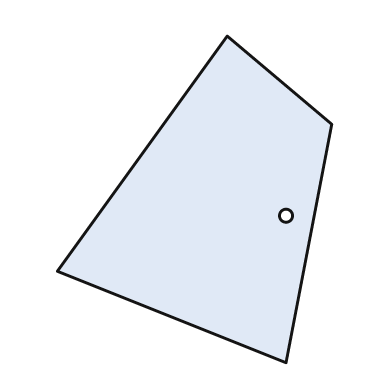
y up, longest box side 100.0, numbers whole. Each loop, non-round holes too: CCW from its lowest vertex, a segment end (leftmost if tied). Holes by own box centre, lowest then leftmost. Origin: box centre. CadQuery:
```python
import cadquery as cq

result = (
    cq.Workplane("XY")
    .moveTo(28.0, -50.0)
    .lineTo(42.0, 23.0)
    .lineTo(10.0, 50.0)
    .lineTo(-42.0, -22.0)
    .close()
    .moveTo(28.0, -5.0)
    .circle(2.0)
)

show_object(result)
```